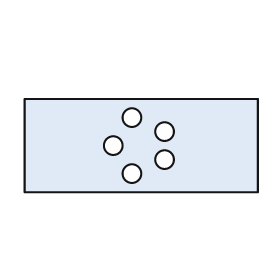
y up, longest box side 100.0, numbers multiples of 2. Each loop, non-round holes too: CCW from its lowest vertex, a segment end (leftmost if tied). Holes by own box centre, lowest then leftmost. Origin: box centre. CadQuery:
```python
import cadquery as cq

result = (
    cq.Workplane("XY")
    .moveTo(-50.0, -20.0)
    .lineTo(50.0, -20.0)
    .lineTo(50.0, 20.0)
    .lineTo(-50.0, 20.0)
    .close()
    .moveTo(-4.0, -12.0)
    .circle(4.0)
    .moveTo(10.0, -6.0)
    .circle(4.0)
    .moveTo(-12.0, 0.0)
    .circle(4.0)
    .moveTo(10.0, 6.0)
    .circle(4.0)
    .moveTo(-4.0, 12.0)
    .circle(4.0)
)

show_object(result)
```